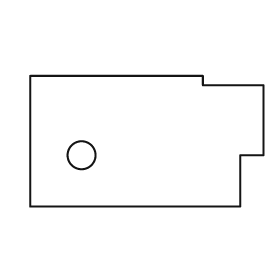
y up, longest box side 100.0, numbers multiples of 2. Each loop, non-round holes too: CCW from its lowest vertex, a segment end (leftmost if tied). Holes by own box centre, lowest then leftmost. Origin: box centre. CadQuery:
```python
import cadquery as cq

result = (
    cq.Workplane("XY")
    .moveTo(-50.0, -28.0)
    .lineTo(40.0, -28.0)
    .lineTo(40.0, -6.0)
    .lineTo(50.0, -6.0)
    .lineTo(50.0, 24.0)
    .lineTo(24.0, 24.0)
    .lineTo(24.0, 28.0)
    .lineTo(-50.0, 28.0)
    .close()
    .moveTo(-28.0, -6.0)
    .circle(6.0)
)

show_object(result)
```